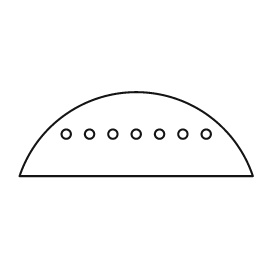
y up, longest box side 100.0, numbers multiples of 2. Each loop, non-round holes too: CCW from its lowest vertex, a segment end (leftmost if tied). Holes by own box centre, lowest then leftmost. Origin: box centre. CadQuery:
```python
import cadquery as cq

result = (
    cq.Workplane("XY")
    .moveTo(-50.0, -18.0)
    .lineTo(50.0, -18.0)
    .threePointArc((0.0, 18.0), (-50.0, -18.0))
    .close()
    .moveTo(-30.0, 0.0)
    .circle(2.0)
    .moveTo(-20.0, 0.0)
    .circle(2.0)
    .moveTo(-10.0, 0.0)
    .circle(2.0)
    .moveTo(0.0, 0.0)
    .circle(2.0)
    .moveTo(10.0, 0.0)
    .circle(2.0)
    .moveTo(20.0, 0.0)
    .circle(2.0)
    .moveTo(30.0, 0.0)
    .circle(2.0)
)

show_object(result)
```